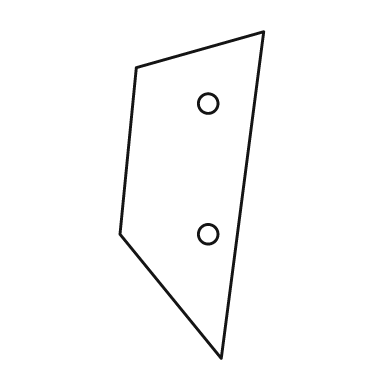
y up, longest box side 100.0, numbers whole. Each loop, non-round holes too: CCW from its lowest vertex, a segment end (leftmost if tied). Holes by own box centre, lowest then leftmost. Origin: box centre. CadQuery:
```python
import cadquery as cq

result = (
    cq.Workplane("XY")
    .moveTo(9.0, -50.0)
    .lineTo(22.0, 50.0)
    .lineTo(-17.0, 39.0)
    .lineTo(-22.0, -12.0)
    .close()
    .moveTo(5.0, -12.0)
    .circle(3.0)
    .moveTo(5.0, 28.0)
    .circle(3.0)
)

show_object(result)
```